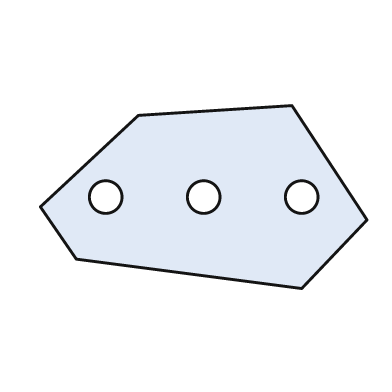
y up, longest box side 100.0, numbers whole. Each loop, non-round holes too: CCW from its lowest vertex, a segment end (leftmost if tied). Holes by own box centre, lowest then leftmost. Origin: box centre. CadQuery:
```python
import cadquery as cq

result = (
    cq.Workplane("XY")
    .moveTo(30.0, -28.0)
    .lineTo(50.0, -7.0)
    .lineTo(27.0, 28.0)
    .lineTo(-20.0, 25.0)
    .lineTo(-50.0, -3.0)
    .lineTo(-39.0, -19.0)
    .close()
    .moveTo(-30.0, 0.0)
    .circle(5.0)
    .moveTo(0.0, 0.0)
    .circle(5.0)
    .moveTo(30.0, 0.0)
    .circle(5.0)
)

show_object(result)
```